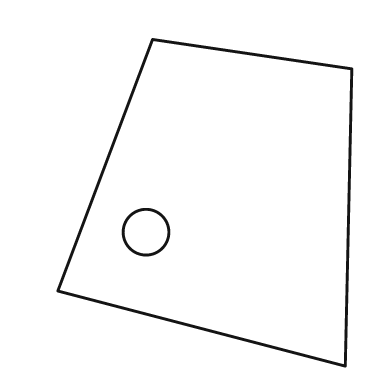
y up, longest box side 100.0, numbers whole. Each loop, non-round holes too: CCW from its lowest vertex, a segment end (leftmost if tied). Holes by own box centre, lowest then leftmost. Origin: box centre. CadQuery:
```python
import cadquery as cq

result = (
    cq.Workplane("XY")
    .moveTo(43.0, -50.0)
    .lineTo(45.0, 41.0)
    .lineTo(-16.0, 50.0)
    .lineTo(-45.0, -27.0)
    .close()
    .moveTo(-18.0, -9.0)
    .circle(7.0)
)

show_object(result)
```